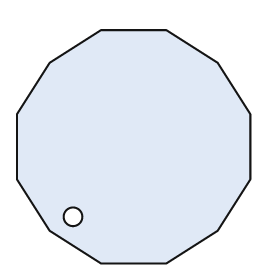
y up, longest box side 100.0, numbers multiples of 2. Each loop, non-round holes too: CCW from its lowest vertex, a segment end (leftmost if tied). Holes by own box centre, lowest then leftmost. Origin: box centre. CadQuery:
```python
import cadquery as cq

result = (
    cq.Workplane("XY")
    .moveTo(-14.0, -50.0)
    .lineTo(14.0, -50.0)
    .lineTo(36.0, -36.0)
    .lineTo(50.0, -14.0)
    .lineTo(50.0, 14.0)
    .lineTo(36.0, 36.0)
    .lineTo(14.0, 50.0)
    .lineTo(-14.0, 50.0)
    .lineTo(-36.0, 36.0)
    .lineTo(-50.0, 14.0)
    .lineTo(-50.0, -14.0)
    .lineTo(-36.0, -36.0)
    .close()
    .moveTo(-26.0, -30.0)
    .circle(4.0)
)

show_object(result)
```